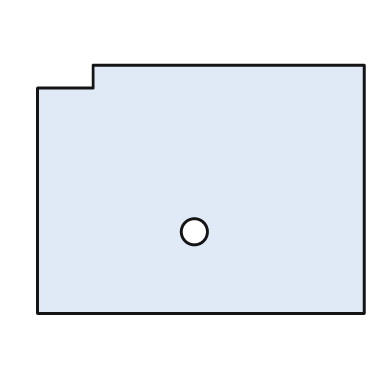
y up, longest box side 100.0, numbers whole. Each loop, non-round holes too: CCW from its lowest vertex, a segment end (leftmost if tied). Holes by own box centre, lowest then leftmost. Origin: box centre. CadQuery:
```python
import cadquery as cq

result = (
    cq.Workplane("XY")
    .moveTo(-50.0, -38.0)
    .lineTo(50.0, -38.0)
    .lineTo(50.0, 38.0)
    .lineTo(-33.0, 38.0)
    .lineTo(-33.0, 31.0)
    .lineTo(-50.0, 31.0)
    .close()
    .moveTo(-2.0, -13.0)
    .circle(4.0)
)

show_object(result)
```